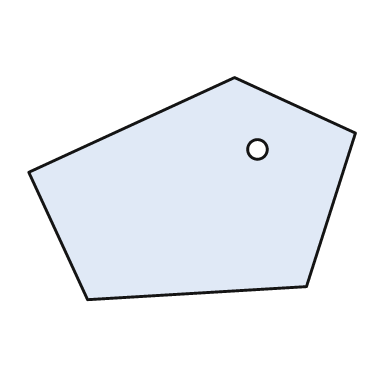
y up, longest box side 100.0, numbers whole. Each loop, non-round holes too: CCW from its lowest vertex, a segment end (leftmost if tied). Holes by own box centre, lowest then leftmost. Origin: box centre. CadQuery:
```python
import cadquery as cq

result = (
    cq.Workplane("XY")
    .moveTo(-32.0, -34.0)
    .lineTo(35.0, -30.0)
    .lineTo(50.0, 17.0)
    .lineTo(13.0, 34.0)
    .lineTo(-50.0, 5.0)
    .close()
    .moveTo(20.0, 12.0)
    .circle(3.0)
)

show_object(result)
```